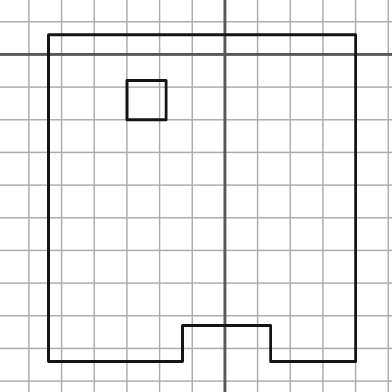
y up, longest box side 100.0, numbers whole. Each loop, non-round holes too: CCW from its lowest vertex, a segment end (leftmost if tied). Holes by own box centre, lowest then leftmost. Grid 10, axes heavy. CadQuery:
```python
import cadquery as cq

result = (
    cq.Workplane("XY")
    .moveTo(-54.0, -94.0)
    .lineTo(-13.0, -94.0)
    .lineTo(-13.0, -83.0)
    .lineTo(14.0, -83.0)
    .lineTo(14.0, -94.0)
    .lineTo(40.0, -94.0)
    .lineTo(40.0, 6.0)
    .lineTo(-54.0, 6.0)
    .close()
    .moveTo(-30.0, -20.0)
    .lineTo(-18.0, -20.0)
    .lineTo(-18.0, -8.0)
    .lineTo(-30.0, -8.0)
    .close()
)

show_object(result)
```